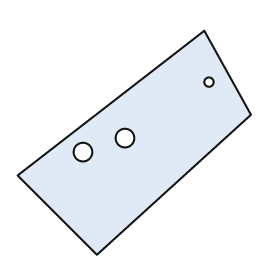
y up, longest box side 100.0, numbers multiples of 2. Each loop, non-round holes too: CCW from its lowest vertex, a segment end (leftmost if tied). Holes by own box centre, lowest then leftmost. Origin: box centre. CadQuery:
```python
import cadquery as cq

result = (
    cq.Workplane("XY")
    .moveTo(-16.0, -48.0)
    .lineTo(50.0, 12.0)
    .lineTo(30.0, 48.0)
    .lineTo(-50.0, -14.0)
    .close()
    .moveTo(-22.0, -4.0)
    .circle(4.0)
    .moveTo(-4.0, 2.0)
    .circle(4.0)
    .moveTo(32.0, 26.0)
    .circle(2.0)
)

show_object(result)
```